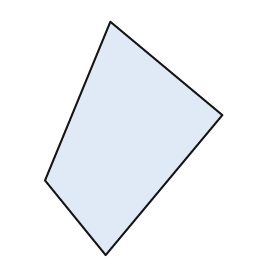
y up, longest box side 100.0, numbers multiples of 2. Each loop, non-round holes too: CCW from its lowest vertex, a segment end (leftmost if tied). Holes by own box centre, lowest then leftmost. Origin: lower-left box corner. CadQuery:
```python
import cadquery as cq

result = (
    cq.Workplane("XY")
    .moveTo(26.0, 0.0)
    .lineTo(76.0, 60.0)
    .lineTo(28.0, 100.0)
    .lineTo(0.0, 32.0)
    .close()
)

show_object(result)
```